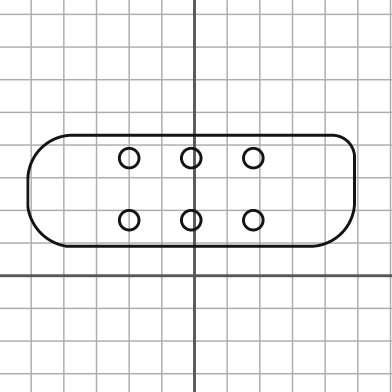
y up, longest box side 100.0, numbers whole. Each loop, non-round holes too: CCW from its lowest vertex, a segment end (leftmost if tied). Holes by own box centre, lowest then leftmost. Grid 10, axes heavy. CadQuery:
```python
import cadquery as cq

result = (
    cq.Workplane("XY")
    .moveTo(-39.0, 9.0)
    .lineTo(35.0, 9.0)
    .threePointArc((45.0, 13.0), (49.0, 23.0))
    .lineTo(49.0, 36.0)
    .threePointArc((47.0, 41.0), (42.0, 43.0))
    .lineTo(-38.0, 43.0)
    .threePointArc((-47.0, 39.0), (-51.0, 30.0))
    .lineTo(-51.0, 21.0)
    .threePointArc((-47.0, 13.0), (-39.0, 9.0))
    .close()
    .moveTo(-20.0, 17.0)
    .circle(3.0)
    .moveTo(-1.0, 17.0)
    .circle(3.0)
    .moveTo(18.0, 17.0)
    .circle(3.0)
    .moveTo(-20.0, 36.0)
    .circle(3.0)
    .moveTo(-1.0, 36.0)
    .circle(3.0)
    .moveTo(18.0, 36.0)
    .circle(3.0)
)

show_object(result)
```